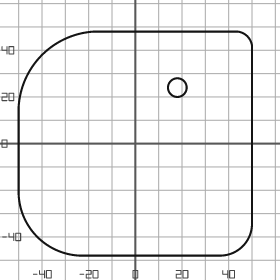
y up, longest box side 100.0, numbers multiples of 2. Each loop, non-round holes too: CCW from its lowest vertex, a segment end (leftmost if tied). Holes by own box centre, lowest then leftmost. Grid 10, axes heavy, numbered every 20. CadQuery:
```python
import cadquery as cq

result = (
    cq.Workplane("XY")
    .moveTo(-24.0, -48.0)
    .lineTo(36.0, -48.0)
    .threePointArc((46.0, -44.0), (50.0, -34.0))
    .lineTo(50.0, 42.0)
    .threePointArc((48.0, 46.0), (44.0, 48.0))
    .lineTo(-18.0, 48.0)
    .threePointArc((-40.0, 38.0), (-50.0, 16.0))
    .lineTo(-50.0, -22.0)
    .threePointArc((-42.0, -40.0), (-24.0, -48.0))
    .close()
    .moveTo(18.0, 24.0)
    .circle(4.0)
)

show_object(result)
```